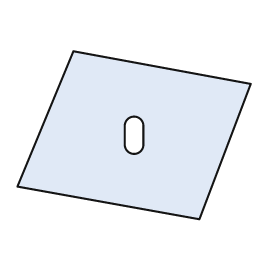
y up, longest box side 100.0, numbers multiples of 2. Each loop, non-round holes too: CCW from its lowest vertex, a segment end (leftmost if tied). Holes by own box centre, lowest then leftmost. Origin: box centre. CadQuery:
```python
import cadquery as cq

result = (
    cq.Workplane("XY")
    .moveTo(28.0, -36.0)
    .lineTo(50.0, 22.0)
    .lineTo(-26.0, 36.0)
    .lineTo(-50.0, -22.0)
    .close()
    .moveTo(-4.0, -4.0)
    .threePointArc((0.0, -8.0), (4.0, -4.0))
    .lineTo(4.0, 4.0)
    .threePointArc((0.0, 8.0), (-4.0, 4.0))
    .close()
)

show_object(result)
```